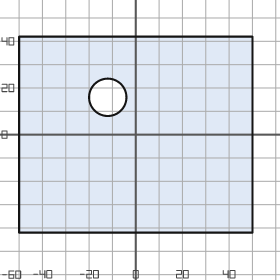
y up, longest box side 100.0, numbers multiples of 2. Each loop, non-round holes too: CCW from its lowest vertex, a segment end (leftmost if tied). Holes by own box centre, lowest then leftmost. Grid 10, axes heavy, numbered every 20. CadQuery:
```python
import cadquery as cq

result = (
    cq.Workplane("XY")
    .moveTo(-50.0, -42.0)
    .lineTo(50.0, -42.0)
    .lineTo(50.0, 42.0)
    .lineTo(-50.0, 42.0)
    .close()
    .moveTo(-12.0, 16.0)
    .circle(8.0)
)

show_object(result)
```